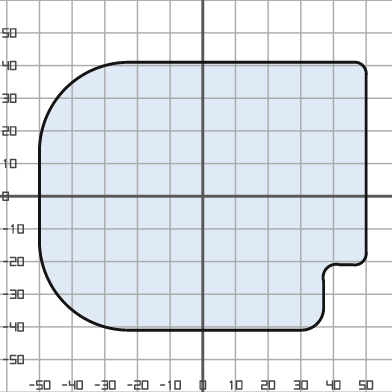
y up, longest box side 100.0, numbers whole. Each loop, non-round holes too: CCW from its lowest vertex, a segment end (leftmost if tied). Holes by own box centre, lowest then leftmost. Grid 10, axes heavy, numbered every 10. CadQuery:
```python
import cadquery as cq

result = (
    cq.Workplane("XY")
    .moveTo(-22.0, -41.0)
    .lineTo(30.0, -41.0)
    .threePointArc((35.0, -39.0), (37.0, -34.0))
    .lineTo(37.0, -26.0)
    .threePointArc((38.0, -22.0), (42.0, -21.0))
    .lineTo(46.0, -21.0)
    .threePointArc((49.0, -20.0), (50.0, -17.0))
    .lineTo(50.0, 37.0)
    .threePointArc((49.0, 40.0), (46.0, 41.0))
    .lineTo(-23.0, 41.0)
    .threePointArc((-42.0, 33.0), (-50.0, 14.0))
    .lineTo(-50.0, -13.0)
    .threePointArc((-42.0, -33.0), (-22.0, -41.0))
    .close()
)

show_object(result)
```